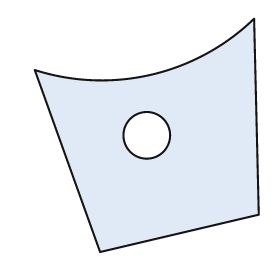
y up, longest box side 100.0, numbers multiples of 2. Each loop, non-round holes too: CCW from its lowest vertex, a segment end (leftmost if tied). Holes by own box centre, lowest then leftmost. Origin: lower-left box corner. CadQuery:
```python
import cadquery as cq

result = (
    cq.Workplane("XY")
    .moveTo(28.0, 0.0)
    .lineTo(96.0, 16.0)
    .lineTo(94.0, 100.0)
    .threePointArc((50.0, 76.0), (0.0, 78.0))
    .close()
    .moveTo(48.0, 50.0)
    .circle(10.0)
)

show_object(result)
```